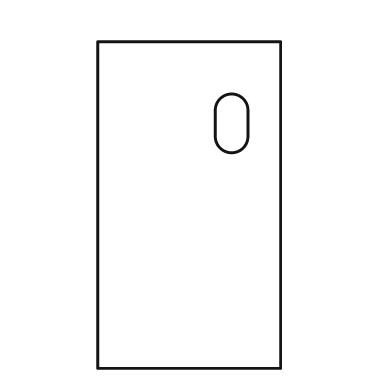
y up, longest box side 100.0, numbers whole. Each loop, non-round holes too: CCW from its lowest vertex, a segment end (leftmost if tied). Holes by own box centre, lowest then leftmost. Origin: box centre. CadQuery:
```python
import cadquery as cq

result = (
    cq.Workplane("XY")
    .moveTo(-28.0, -50.0)
    .lineTo(28.0, -50.0)
    .lineTo(28.0, 50.0)
    .lineTo(-28.0, 50.0)
    .close()
    .moveTo(8.0, 21.0)
    .threePointArc((13.0, 16.0), (18.0, 21.0))
    .lineTo(18.0, 29.0)
    .threePointArc((13.0, 34.0), (8.0, 29.0))
    .close()
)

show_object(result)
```